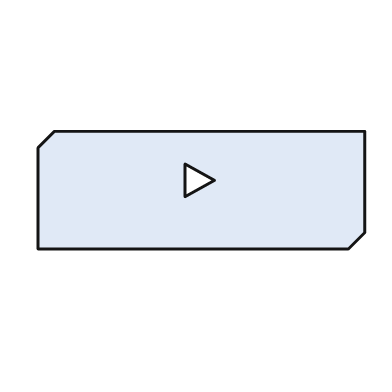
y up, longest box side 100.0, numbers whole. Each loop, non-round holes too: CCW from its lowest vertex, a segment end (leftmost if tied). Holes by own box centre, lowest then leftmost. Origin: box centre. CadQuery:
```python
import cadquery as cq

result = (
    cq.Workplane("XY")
    .moveTo(-50.0, -18.0)
    .lineTo(45.0, -18.0)
    .lineTo(50.0, -13.0)
    .lineTo(50.0, 18.0)
    .lineTo(-45.0, 18.0)
    .lineTo(-50.0, 13.0)
    .close()
    .moveTo(-5.0, -2.0)
    .lineTo(4.0, 3.0)
    .lineTo(-5.0, 8.0)
    .close()
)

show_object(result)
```